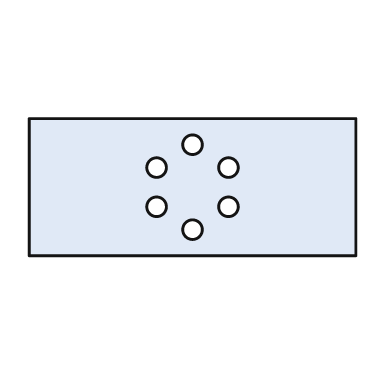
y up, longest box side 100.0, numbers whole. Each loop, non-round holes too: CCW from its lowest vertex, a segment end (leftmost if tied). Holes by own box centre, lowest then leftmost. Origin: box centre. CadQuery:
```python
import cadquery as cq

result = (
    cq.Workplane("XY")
    .moveTo(-50.0, -21.0)
    .lineTo(50.0, -21.0)
    .lineTo(50.0, 21.0)
    .lineTo(-50.0, 21.0)
    .close()
    .moveTo(0.0, -13.0)
    .circle(3.0)
    .moveTo(-11.0, -6.0)
    .circle(3.0)
    .moveTo(11.0, -6.0)
    .circle(3.0)
    .moveTo(-11.0, 6.0)
    .circle(3.0)
    .moveTo(11.0, 6.0)
    .circle(3.0)
    .moveTo(0.0, 13.0)
    .circle(3.0)
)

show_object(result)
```